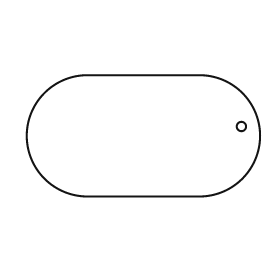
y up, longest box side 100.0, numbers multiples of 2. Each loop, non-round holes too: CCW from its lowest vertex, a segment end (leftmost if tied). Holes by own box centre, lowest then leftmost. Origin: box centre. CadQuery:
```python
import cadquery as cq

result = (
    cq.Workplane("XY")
    .moveTo(-24.0, -26.0)
    .lineTo(24.0, -26.0)
    .threePointArc((50.0, 0.0), (24.0, 26.0))
    .lineTo(-24.0, 26.0)
    .threePointArc((-50.0, 0.0), (-24.0, -26.0))
    .close()
    .moveTo(42.0, 4.0)
    .circle(2.0)
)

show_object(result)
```